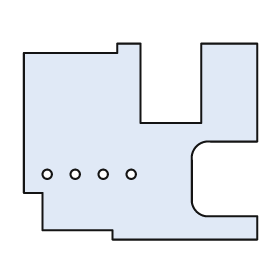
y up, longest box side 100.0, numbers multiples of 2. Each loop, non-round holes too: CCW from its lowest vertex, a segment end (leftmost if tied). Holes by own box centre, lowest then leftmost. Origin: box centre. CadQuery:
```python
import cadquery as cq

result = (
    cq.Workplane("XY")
    .moveTo(-12.0, -42.0)
    .lineTo(50.0, -42.0)
    .lineTo(50.0, -32.0)
    .lineTo(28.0, -32.0)
    .threePointArc((24.0, -30.0), (22.0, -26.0))
    .lineTo(22.0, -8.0)
    .threePointArc((24.0, -2.0), (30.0, 0.0))
    .lineTo(50.0, 0.0)
    .lineTo(50.0, 42.0)
    .lineTo(26.0, 42.0)
    .lineTo(26.0, 8.0)
    .lineTo(0.0, 8.0)
    .lineTo(0.0, 42.0)
    .lineTo(-10.0, 42.0)
    .lineTo(-10.0, 38.0)
    .lineTo(-50.0, 38.0)
    .lineTo(-50.0, -22.0)
    .lineTo(-42.0, -22.0)
    .lineTo(-42.0, -38.0)
    .lineTo(-12.0, -38.0)
    .close()
    .moveTo(-40.0, -14.0)
    .circle(2.0)
    .moveTo(-28.0, -14.0)
    .circle(2.0)
    .moveTo(-16.0, -14.0)
    .circle(2.0)
    .moveTo(-4.0, -14.0)
    .circle(2.0)
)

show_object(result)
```